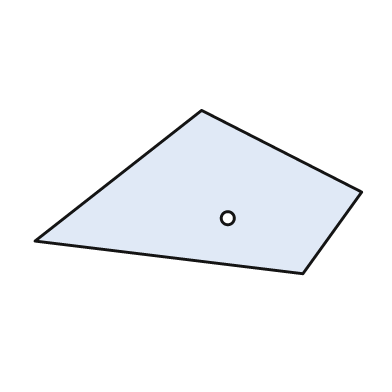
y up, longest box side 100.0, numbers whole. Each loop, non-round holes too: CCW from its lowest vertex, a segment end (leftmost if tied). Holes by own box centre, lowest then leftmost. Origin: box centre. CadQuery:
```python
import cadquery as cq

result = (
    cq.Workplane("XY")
    .moveTo(32.0, -25.0)
    .lineTo(50.0, 0.0)
    .lineTo(1.0, 25.0)
    .lineTo(-50.0, -15.0)
    .close()
    .moveTo(9.0, -8.0)
    .circle(2.0)
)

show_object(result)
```